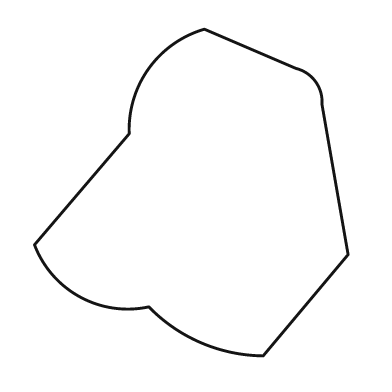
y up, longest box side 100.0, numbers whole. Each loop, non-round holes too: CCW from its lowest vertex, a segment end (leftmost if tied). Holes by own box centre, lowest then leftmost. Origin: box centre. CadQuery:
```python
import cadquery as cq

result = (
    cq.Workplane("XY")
    .moveTo(22.0, -50.0)
    .lineTo(48.0, -19.0)
    .lineTo(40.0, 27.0)
    .threePointArc((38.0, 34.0), (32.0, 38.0))
    .lineTo(4.0, 50.0)
    .threePointArc((-13.0, 38.0), (-19.0, 18.0))
    .lineTo(-48.0, -16.0)
    .threePointArc((-34.0, -32.0), (-13.0, -35.0))
    .threePointArc((3.0, -46.0), (22.0, -50.0))
    .close()
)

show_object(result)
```